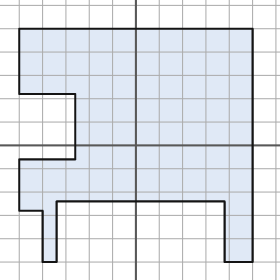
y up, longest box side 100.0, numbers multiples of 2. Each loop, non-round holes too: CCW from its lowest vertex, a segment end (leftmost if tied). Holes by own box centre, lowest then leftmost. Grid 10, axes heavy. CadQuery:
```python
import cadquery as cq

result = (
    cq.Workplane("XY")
    .moveTo(-40.0, -50.0)
    .lineTo(-34.0, -50.0)
    .lineTo(-34.0, -24.0)
    .lineTo(38.0, -24.0)
    .lineTo(38.0, -50.0)
    .lineTo(50.0, -50.0)
    .lineTo(50.0, 50.0)
    .lineTo(-50.0, 50.0)
    .lineTo(-50.0, 22.0)
    .lineTo(-26.0, 22.0)
    .lineTo(-26.0, -6.0)
    .lineTo(-50.0, -6.0)
    .lineTo(-50.0, -28.0)
    .lineTo(-40.0, -28.0)
    .close()
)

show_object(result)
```